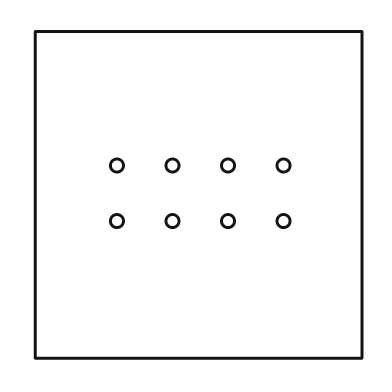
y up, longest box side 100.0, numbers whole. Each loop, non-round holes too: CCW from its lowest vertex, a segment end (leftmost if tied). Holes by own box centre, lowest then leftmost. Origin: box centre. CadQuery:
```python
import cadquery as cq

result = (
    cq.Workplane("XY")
    .moveTo(-50.0, -50.0)
    .lineTo(50.0, -50.0)
    .lineTo(50.0, 50.0)
    .lineTo(-50.0, 50.0)
    .close()
    .moveTo(-25.0, -8.0)
    .circle(2.0)
    .moveTo(-8.0, -8.0)
    .circle(2.0)
    .moveTo(9.0, -8.0)
    .circle(2.0)
    .moveTo(26.0, -8.0)
    .circle(2.0)
    .moveTo(-25.0, 9.0)
    .circle(2.0)
    .moveTo(-8.0, 9.0)
    .circle(2.0)
    .moveTo(9.0, 9.0)
    .circle(2.0)
    .moveTo(26.0, 9.0)
    .circle(2.0)
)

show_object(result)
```